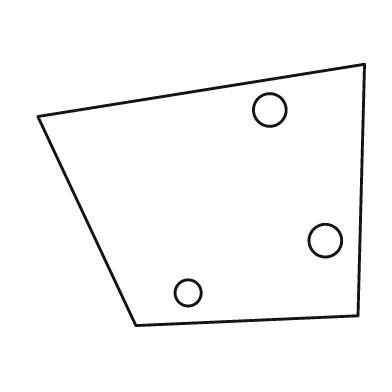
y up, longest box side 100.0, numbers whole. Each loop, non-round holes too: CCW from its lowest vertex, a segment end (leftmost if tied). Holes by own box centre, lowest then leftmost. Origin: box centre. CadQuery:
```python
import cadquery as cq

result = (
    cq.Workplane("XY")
    .moveTo(-20.0, -40.0)
    .lineTo(48.0, -37.0)
    .lineTo(50.0, 40.0)
    .lineTo(-50.0, 24.0)
    .close()
    .moveTo(-4.0, -30.0)
    .circle(4.0)
    .moveTo(38.0, -14.0)
    .circle(5.0)
    .moveTo(21.0, 26.0)
    .circle(5.0)
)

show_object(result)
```